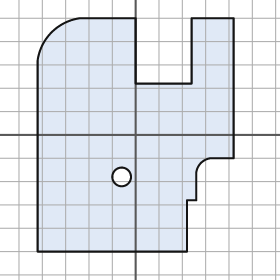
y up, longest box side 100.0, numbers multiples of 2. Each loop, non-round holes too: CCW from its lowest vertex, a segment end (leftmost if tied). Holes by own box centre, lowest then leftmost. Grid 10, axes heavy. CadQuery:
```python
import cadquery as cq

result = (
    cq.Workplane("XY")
    .moveTo(-42.0, -50.0)
    .lineTo(22.0, -50.0)
    .lineTo(22.0, -28.0)
    .lineTo(26.0, -28.0)
    .lineTo(26.0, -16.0)
    .threePointArc((28.0, -12.0), (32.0, -10.0))
    .lineTo(42.0, -10.0)
    .lineTo(42.0, 50.0)
    .lineTo(24.0, 50.0)
    .lineTo(24.0, 22.0)
    .lineTo(0.0, 22.0)
    .lineTo(0.0, 50.0)
    .lineTo(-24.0, 50.0)
    .threePointArc((-36.0, 44.0), (-42.0, 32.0))
    .close()
    .moveTo(-6.0, -18.0)
    .circle(4.0)
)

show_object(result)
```